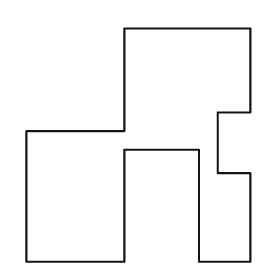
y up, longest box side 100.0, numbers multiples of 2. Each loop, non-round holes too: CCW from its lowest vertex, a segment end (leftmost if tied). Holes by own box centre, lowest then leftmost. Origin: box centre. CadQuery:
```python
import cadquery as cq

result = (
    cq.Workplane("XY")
    .moveTo(-48.0, -50.0)
    .lineTo(-6.0, -50.0)
    .lineTo(-6.0, -2.0)
    .lineTo(26.0, -2.0)
    .lineTo(26.0, -50.0)
    .lineTo(48.0, -50.0)
    .lineTo(48.0, -12.0)
    .lineTo(34.0, -12.0)
    .lineTo(34.0, 14.0)
    .lineTo(48.0, 14.0)
    .lineTo(48.0, 50.0)
    .lineTo(-6.0, 50.0)
    .lineTo(-6.0, 6.0)
    .lineTo(-48.0, 6.0)
    .close()
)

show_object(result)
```